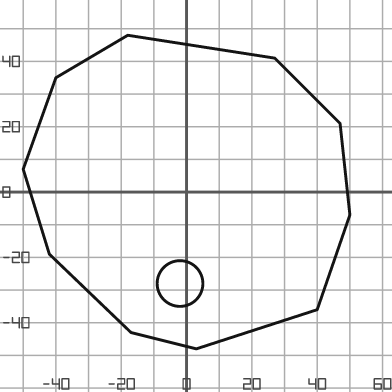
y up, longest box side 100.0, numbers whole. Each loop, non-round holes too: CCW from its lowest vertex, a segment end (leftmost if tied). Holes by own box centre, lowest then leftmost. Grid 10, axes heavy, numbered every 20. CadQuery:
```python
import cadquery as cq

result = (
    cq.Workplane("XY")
    .moveTo(3.0, -48.0)
    .lineTo(40.0, -36.0)
    .lineTo(50.0, -7.0)
    .lineTo(47.0, 21.0)
    .lineTo(27.0, 41.0)
    .lineTo(-18.0, 48.0)
    .lineTo(-40.0, 35.0)
    .lineTo(-50.0, 7.0)
    .lineTo(-42.0, -19.0)
    .lineTo(-17.0, -43.0)
    .close()
    .moveTo(-2.0, -28.0)
    .circle(7.0)
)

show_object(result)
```